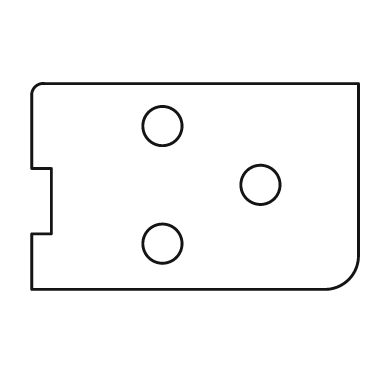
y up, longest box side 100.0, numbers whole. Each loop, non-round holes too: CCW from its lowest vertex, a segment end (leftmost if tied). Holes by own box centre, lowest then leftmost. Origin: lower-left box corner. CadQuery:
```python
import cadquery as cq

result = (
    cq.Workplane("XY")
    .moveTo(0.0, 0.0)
    .lineTo(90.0, 0.0)
    .threePointArc((97.0, 3.0), (100.0, 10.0))
    .lineTo(100.0, 63.0)
    .lineTo(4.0, 63.0)
    .threePointArc((1.0, 62.0), (0.0, 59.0))
    .lineTo(0.0, 37.0)
    .lineTo(6.0, 37.0)
    .lineTo(6.0, 17.0)
    .lineTo(0.0, 17.0)
    .close()
    .moveTo(40.0, 14.0)
    .circle(6.0)
    .moveTo(70.0, 32.0)
    .circle(6.0)
    .moveTo(40.0, 50.0)
    .circle(6.0)
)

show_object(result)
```